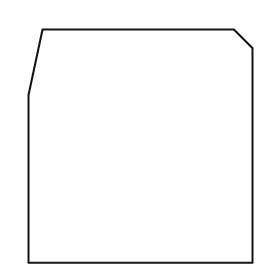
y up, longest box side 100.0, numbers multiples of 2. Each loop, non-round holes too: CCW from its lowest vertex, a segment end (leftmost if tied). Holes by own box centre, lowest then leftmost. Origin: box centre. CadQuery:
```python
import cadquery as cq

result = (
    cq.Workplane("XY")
    .moveTo(-48.0, -50.0)
    .lineTo(48.0, -50.0)
    .lineTo(48.0, 42.0)
    .lineTo(40.0, 50.0)
    .lineTo(-42.0, 50.0)
    .lineTo(-48.0, 22.0)
    .close()
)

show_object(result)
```